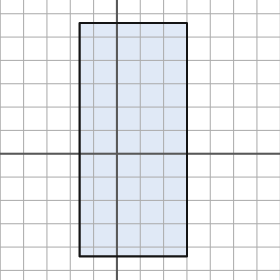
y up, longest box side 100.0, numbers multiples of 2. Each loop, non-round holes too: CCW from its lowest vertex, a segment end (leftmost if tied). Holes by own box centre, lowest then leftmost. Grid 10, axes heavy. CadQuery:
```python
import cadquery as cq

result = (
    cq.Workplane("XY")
    .moveTo(-16.0, -44.0)
    .lineTo(30.0, -44.0)
    .lineTo(30.0, 56.0)
    .lineTo(-16.0, 56.0)
    .close()
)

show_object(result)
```